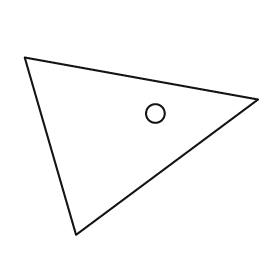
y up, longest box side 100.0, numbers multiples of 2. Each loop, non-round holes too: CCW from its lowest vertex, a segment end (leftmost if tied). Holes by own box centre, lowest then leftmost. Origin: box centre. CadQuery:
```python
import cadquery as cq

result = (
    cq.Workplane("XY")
    .moveTo(-28.0, -38.0)
    .lineTo(50.0, 20.0)
    .lineTo(-50.0, 38.0)
    .close()
    .moveTo(6.0, 14.0)
    .circle(4.0)
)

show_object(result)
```